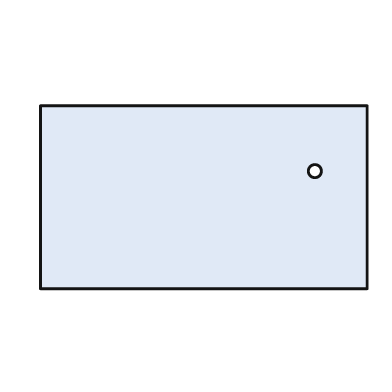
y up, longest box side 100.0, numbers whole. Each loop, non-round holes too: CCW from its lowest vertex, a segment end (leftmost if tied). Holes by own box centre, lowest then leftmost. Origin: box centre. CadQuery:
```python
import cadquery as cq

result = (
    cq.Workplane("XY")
    .moveTo(-50.0, -28.0)
    .lineTo(50.0, -28.0)
    .lineTo(50.0, 28.0)
    .lineTo(-50.0, 28.0)
    .close()
    .moveTo(34.0, 8.0)
    .circle(2.0)
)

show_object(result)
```